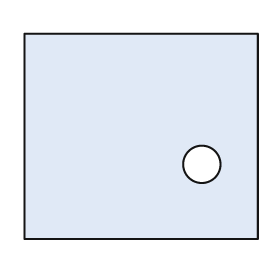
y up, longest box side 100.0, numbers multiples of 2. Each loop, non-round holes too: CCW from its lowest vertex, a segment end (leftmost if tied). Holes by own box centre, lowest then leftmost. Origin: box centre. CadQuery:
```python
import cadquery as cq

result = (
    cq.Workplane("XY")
    .moveTo(-50.0, -44.0)
    .lineTo(50.0, -44.0)
    .lineTo(50.0, 44.0)
    .lineTo(-50.0, 44.0)
    .close()
    .moveTo(26.0, -12.0)
    .circle(8.0)
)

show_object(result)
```